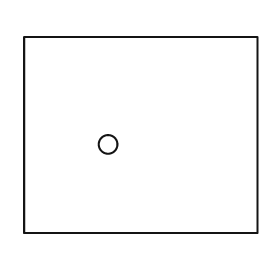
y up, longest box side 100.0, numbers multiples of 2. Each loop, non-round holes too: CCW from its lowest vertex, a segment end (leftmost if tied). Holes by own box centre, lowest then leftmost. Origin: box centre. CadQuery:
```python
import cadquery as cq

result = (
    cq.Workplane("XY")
    .moveTo(-50.0, -42.0)
    .lineTo(50.0, -42.0)
    .lineTo(50.0, 42.0)
    .lineTo(-50.0, 42.0)
    .close()
    .moveTo(-14.0, -4.0)
    .circle(4.0)
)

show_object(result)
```